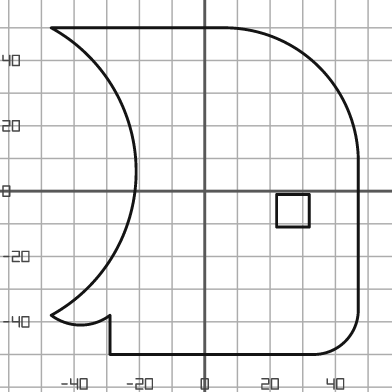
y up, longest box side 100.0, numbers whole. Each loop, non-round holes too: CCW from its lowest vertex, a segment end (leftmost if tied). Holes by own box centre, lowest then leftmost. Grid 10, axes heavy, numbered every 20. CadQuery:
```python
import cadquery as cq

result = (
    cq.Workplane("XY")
    .moveTo(-29.0, -50.0)
    .lineTo(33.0, -50.0)
    .threePointArc((43.0, -46.0), (47.0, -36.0))
    .lineTo(47.0, 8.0)
    .threePointArc((35.0, 38.0), (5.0, 50.0))
    .lineTo(-47.0, 50.0)
    .threePointArc((-21.0, 6.0), (-47.0, -38.0))
    .threePointArc((-38.0, -41.0), (-29.0, -38.0))
    .close()
    .moveTo(22.0, -11.0)
    .lineTo(32.0, -11.0)
    .lineTo(32.0, -1.0)
    .lineTo(22.0, -1.0)
    .close()
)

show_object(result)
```